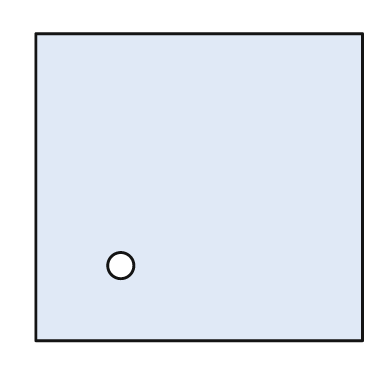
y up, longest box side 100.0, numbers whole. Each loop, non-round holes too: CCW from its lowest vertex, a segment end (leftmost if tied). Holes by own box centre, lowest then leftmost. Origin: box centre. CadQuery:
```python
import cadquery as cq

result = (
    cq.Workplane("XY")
    .moveTo(-50.0, -47.0)
    .lineTo(50.0, -47.0)
    .lineTo(50.0, 47.0)
    .lineTo(-50.0, 47.0)
    .close()
    .moveTo(-24.0, -24.0)
    .circle(4.0)
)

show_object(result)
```